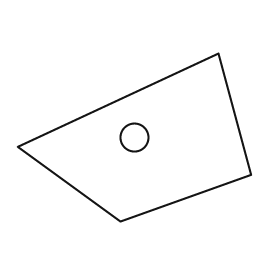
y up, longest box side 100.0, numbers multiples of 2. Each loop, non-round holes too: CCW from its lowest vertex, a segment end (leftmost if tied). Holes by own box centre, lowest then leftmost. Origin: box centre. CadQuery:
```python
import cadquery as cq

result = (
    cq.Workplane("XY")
    .moveTo(-6.0, -36.0)
    .lineTo(50.0, -16.0)
    .lineTo(36.0, 36.0)
    .lineTo(-50.0, -4.0)
    .close()
    .moveTo(0.0, 0.0)
    .circle(6.0)
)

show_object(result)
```